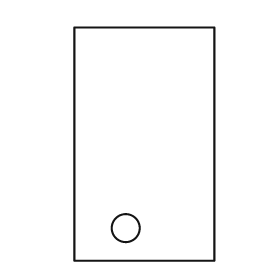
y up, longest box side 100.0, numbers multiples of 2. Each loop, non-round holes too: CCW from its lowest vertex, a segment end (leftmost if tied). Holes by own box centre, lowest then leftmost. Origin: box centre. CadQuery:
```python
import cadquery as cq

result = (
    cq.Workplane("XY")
    .moveTo(-30.0, -50.0)
    .lineTo(30.0, -50.0)
    .lineTo(30.0, 50.0)
    .lineTo(-30.0, 50.0)
    .close()
    .moveTo(-8.0, -36.0)
    .circle(6.0)
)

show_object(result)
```